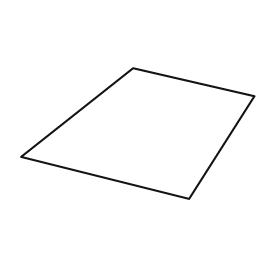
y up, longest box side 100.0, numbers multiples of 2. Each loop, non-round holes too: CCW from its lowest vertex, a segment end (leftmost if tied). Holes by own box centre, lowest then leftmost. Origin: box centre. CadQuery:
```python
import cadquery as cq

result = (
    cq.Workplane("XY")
    .moveTo(22.0, -28.0)
    .lineTo(50.0, 16.0)
    .lineTo(-2.0, 28.0)
    .lineTo(-50.0, -10.0)
    .close()
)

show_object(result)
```